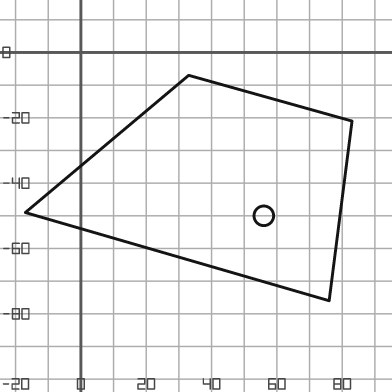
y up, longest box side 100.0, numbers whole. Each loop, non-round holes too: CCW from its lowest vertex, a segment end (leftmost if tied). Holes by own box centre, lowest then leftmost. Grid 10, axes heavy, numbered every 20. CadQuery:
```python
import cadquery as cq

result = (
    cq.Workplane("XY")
    .moveTo(76.0, -76.0)
    .lineTo(83.0, -21.0)
    .lineTo(33.0, -7.0)
    .lineTo(-17.0, -49.0)
    .close()
    .moveTo(56.0, -50.0)
    .circle(3.0)
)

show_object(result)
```